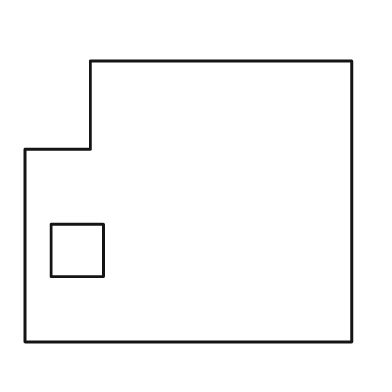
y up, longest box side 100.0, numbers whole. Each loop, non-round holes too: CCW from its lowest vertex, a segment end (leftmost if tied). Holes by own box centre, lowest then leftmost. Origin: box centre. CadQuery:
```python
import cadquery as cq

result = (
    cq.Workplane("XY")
    .moveTo(-50.0, -43.0)
    .lineTo(50.0, -43.0)
    .lineTo(50.0, 43.0)
    .lineTo(-30.0, 43.0)
    .lineTo(-30.0, 16.0)
    .lineTo(-50.0, 16.0)
    .close()
    .moveTo(-42.0, -23.0)
    .lineTo(-26.0, -23.0)
    .lineTo(-26.0, -7.0)
    .lineTo(-42.0, -7.0)
    .close()
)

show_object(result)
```